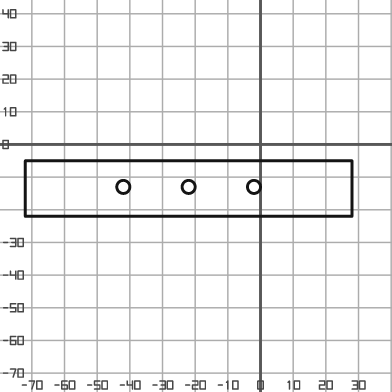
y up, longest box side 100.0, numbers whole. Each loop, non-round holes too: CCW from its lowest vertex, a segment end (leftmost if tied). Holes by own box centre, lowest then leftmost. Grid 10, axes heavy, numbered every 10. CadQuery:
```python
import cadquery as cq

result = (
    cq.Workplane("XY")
    .moveTo(-72.0, -22.0)
    .lineTo(28.0, -22.0)
    .lineTo(28.0, -5.0)
    .lineTo(-72.0, -5.0)
    .close()
    .moveTo(-42.0, -13.0)
    .circle(2.0)
    .moveTo(-22.0, -13.0)
    .circle(2.0)
    .moveTo(-2.0, -13.0)
    .circle(2.0)
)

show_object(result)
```